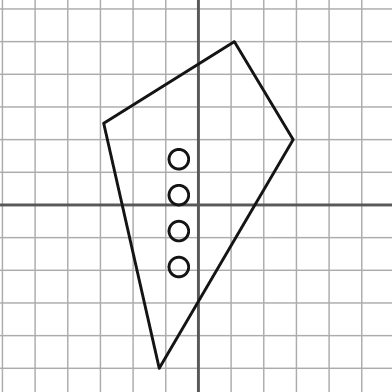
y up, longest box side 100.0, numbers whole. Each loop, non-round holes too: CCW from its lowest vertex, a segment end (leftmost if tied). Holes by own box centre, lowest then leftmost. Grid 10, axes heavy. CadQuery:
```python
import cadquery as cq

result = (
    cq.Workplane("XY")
    .moveTo(-12.0, -50.0)
    .lineTo(29.0, 20.0)
    .lineTo(11.0, 50.0)
    .lineTo(-29.0, 25.0)
    .close()
    .moveTo(-6.0, -19.0)
    .circle(3.0)
    .moveTo(-6.0, -8.0)
    .circle(3.0)
    .moveTo(-6.0, 3.0)
    .circle(3.0)
    .moveTo(-6.0, 14.0)
    .circle(3.0)
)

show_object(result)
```